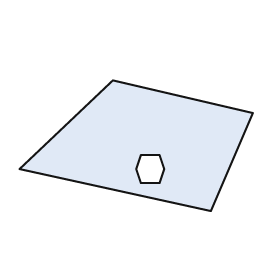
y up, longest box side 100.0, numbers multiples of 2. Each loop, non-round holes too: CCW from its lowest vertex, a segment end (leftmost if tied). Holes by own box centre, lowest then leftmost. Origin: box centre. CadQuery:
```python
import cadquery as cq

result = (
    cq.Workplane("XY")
    .moveTo(32.0, -28.0)
    .lineTo(50.0, 14.0)
    .lineTo(-10.0, 28.0)
    .lineTo(-50.0, -10.0)
    .close()
    .moveTo(2.0, -16.0)
    .lineTo(10.0, -16.0)
    .lineTo(12.0, -10.0)
    .lineTo(10.0, -4.0)
    .lineTo(2.0, -4.0)
    .lineTo(0.0, -10.0)
    .close()
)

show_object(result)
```